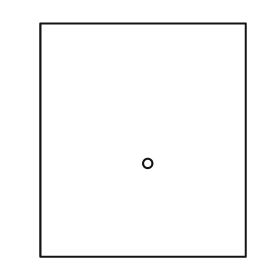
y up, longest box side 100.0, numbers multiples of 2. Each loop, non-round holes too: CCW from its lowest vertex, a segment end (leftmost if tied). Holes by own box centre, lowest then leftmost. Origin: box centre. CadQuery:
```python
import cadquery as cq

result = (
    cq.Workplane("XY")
    .moveTo(-44.0, -50.0)
    .lineTo(44.0, -50.0)
    .lineTo(44.0, 50.0)
    .lineTo(-44.0, 50.0)
    .close()
    .moveTo(2.0, -10.0)
    .circle(2.0)
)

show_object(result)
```